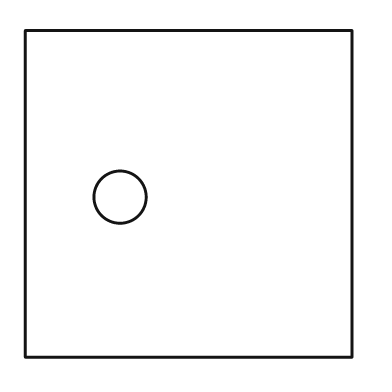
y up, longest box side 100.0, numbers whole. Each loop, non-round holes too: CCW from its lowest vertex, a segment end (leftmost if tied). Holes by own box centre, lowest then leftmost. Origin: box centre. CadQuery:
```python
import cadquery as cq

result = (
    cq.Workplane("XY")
    .moveTo(-50.0, -50.0)
    .lineTo(50.0, -50.0)
    .lineTo(50.0, 50.0)
    .lineTo(-50.0, 50.0)
    .close()
    .moveTo(-21.0, -1.0)
    .circle(8.0)
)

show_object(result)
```